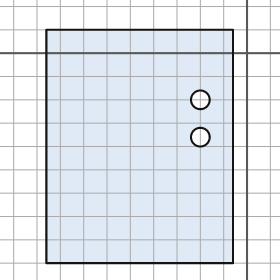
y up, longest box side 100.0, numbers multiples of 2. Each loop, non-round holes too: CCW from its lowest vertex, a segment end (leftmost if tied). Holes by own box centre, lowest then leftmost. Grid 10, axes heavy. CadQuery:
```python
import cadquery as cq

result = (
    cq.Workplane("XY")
    .moveTo(-86.0, -90.0)
    .lineTo(-6.0, -90.0)
    .lineTo(-6.0, 10.0)
    .lineTo(-86.0, 10.0)
    .close()
    .moveTo(-20.0, -36.0)
    .circle(4.0)
    .moveTo(-20.0, -20.0)
    .circle(4.0)
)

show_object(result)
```